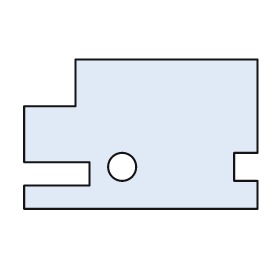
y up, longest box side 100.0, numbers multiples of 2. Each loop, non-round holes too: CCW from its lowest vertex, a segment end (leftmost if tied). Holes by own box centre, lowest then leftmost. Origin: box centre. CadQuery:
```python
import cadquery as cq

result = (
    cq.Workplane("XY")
    .moveTo(-50.0, -32.0)
    .lineTo(50.0, -32.0)
    .lineTo(50.0, -20.0)
    .lineTo(40.0, -20.0)
    .lineTo(40.0, -8.0)
    .lineTo(50.0, -8.0)
    .lineTo(50.0, 32.0)
    .lineTo(-28.0, 32.0)
    .lineTo(-28.0, 12.0)
    .lineTo(-50.0, 12.0)
    .lineTo(-50.0, -12.0)
    .lineTo(-22.0, -12.0)
    .lineTo(-22.0, -22.0)
    .lineTo(-50.0, -22.0)
    .close()
    .moveTo(-8.0, -14.0)
    .circle(6.0)
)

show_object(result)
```